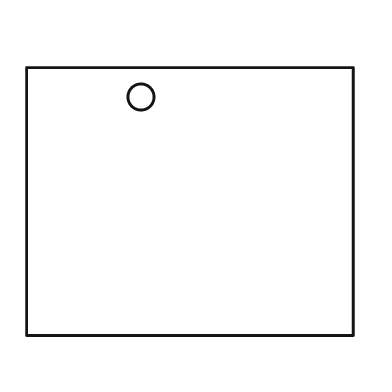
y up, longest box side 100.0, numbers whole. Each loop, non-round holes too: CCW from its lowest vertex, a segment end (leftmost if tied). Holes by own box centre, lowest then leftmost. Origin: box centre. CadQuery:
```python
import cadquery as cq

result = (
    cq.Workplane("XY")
    .moveTo(-50.0, -41.0)
    .lineTo(50.0, -41.0)
    .lineTo(50.0, 41.0)
    .lineTo(-50.0, 41.0)
    .close()
    .moveTo(-15.0, 32.0)
    .circle(4.0)
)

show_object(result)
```